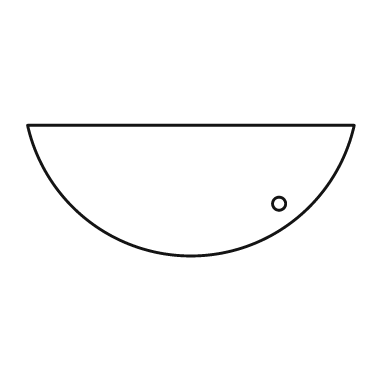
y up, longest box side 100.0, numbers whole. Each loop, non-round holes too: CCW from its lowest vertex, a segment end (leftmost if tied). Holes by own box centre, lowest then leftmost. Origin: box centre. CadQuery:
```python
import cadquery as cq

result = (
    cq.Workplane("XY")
    .moveTo(-50.0, 20.0)
    .threePointArc((0.0, -20.0), (50.0, 20.0))
    .close()
    .moveTo(27.0, -4.0)
    .circle(2.0)
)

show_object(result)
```